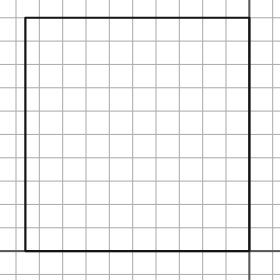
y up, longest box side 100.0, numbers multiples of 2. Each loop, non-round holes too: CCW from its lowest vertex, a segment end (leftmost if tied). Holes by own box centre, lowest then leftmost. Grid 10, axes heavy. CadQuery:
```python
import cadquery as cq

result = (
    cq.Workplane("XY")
    .moveTo(-96.0, 0.0)
    .lineTo(0.0, 0.0)
    .lineTo(0.0, 100.0)
    .lineTo(-96.0, 100.0)
    .close()
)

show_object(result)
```